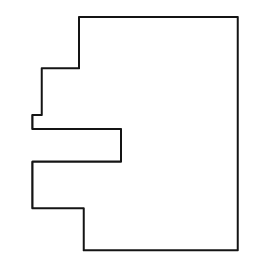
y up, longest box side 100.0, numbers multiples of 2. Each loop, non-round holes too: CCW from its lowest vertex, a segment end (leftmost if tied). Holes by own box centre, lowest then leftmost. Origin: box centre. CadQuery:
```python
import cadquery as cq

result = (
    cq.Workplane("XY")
    .moveTo(-22.0, -50.0)
    .lineTo(44.0, -50.0)
    .lineTo(44.0, 50.0)
    .lineTo(-24.0, 50.0)
    .lineTo(-24.0, 28.0)
    .lineTo(-40.0, 28.0)
    .lineTo(-40.0, 8.0)
    .lineTo(-44.0, 8.0)
    .lineTo(-44.0, 2.0)
    .lineTo(-6.0, 2.0)
    .lineTo(-6.0, -12.0)
    .lineTo(-44.0, -12.0)
    .lineTo(-44.0, -32.0)
    .lineTo(-22.0, -32.0)
    .close()
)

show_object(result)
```